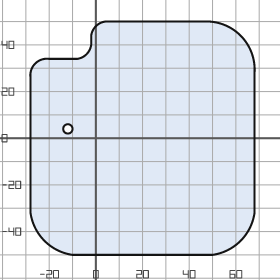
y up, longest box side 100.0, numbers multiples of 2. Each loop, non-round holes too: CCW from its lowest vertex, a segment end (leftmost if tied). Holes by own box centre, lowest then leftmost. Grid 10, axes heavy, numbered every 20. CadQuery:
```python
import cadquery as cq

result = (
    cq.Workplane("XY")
    .moveTo(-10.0, -50.0)
    .lineTo(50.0, -50.0)
    .threePointArc((62.0, -44.0), (68.0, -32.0))
    .lineTo(68.0, 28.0)
    .threePointArc((62.0, 44.0), (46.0, 50.0))
    .lineTo(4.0, 50.0)
    .threePointArc((0.0, 48.0), (-2.0, 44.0))
    .lineTo(-2.0, 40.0)
    .threePointArc((-4.0, 36.0), (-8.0, 34.0))
    .lineTo(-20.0, 34.0)
    .threePointArc((-26.0, 32.0), (-28.0, 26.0))
    .lineTo(-28.0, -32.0)
    .threePointArc((-22.0, -44.0), (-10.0, -50.0))
    .close()
    .moveTo(-12.0, 4.0)
    .circle(2.0)
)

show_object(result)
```